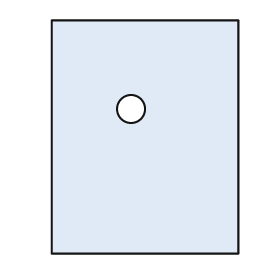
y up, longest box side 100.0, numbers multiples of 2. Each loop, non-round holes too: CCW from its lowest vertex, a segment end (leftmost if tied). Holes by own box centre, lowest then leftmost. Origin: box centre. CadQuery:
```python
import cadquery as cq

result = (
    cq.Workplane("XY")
    .moveTo(-40.0, -50.0)
    .lineTo(40.0, -50.0)
    .lineTo(40.0, 50.0)
    .lineTo(-40.0, 50.0)
    .close()
    .moveTo(-6.0, 12.0)
    .circle(6.0)
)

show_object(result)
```